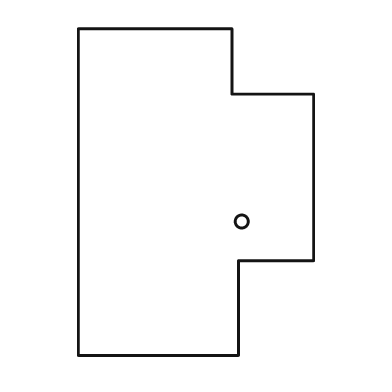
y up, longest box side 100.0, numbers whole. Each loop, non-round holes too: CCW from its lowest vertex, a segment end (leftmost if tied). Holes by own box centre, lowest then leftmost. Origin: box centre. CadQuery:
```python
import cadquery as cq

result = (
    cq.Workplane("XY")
    .moveTo(-36.0, -50.0)
    .lineTo(13.0, -50.0)
    .lineTo(13.0, -21.0)
    .lineTo(36.0, -21.0)
    .lineTo(36.0, 30.0)
    .lineTo(11.0, 30.0)
    .lineTo(11.0, 50.0)
    .lineTo(-36.0, 50.0)
    .close()
    .moveTo(14.0, -9.0)
    .circle(2.0)
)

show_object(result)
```